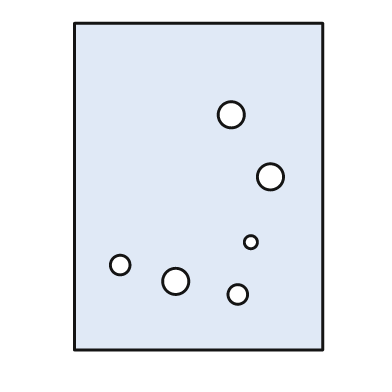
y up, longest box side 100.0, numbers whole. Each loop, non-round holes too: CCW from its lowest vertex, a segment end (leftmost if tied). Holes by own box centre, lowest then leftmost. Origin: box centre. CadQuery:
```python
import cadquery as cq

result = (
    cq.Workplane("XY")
    .moveTo(-38.0, -50.0)
    .lineTo(38.0, -50.0)
    .lineTo(38.0, 50.0)
    .lineTo(-38.0, 50.0)
    .close()
    .moveTo(12.0, -33.0)
    .circle(3.0)
    .moveTo(-7.0, -29.0)
    .circle(4.0)
    .moveTo(-24.0, -24.0)
    .circle(3.0)
    .moveTo(16.0, -17.0)
    .circle(2.0)
    .moveTo(22.0, 3.0)
    .circle(4.0)
    .moveTo(10.0, 22.0)
    .circle(4.0)
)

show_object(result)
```